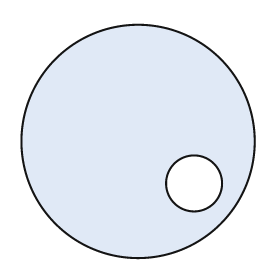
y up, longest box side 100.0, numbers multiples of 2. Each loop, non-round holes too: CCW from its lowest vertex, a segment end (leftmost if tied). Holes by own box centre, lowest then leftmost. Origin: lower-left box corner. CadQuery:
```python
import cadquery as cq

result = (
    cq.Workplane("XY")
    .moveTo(50.0, 50.0)
    .circle(50.0)
    .moveTo(74.0, 32.0)
    .circle(12.0)
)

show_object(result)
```